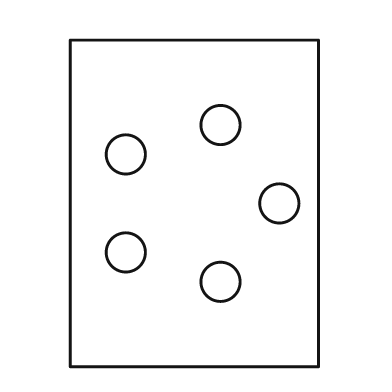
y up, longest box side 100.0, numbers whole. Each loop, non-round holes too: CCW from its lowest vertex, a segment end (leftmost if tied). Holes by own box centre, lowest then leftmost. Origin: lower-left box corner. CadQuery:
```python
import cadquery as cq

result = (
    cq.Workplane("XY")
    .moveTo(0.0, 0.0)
    .lineTo(76.0, 0.0)
    .lineTo(76.0, 100.0)
    .lineTo(0.0, 100.0)
    .close()
    .moveTo(46.0, 26.0)
    .circle(6.0)
    .moveTo(17.0, 35.0)
    .circle(6.0)
    .moveTo(64.0, 50.0)
    .circle(6.0)
    .moveTo(17.0, 65.0)
    .circle(6.0)
    .moveTo(46.0, 74.0)
    .circle(6.0)
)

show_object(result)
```